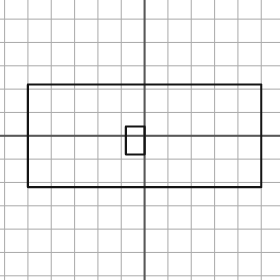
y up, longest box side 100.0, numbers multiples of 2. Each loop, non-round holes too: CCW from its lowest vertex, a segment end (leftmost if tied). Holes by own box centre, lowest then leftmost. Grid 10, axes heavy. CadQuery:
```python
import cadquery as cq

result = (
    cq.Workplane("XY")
    .moveTo(-50.0, -22.0)
    .lineTo(50.0, -22.0)
    .lineTo(50.0, 22.0)
    .lineTo(-50.0, 22.0)
    .close()
    .moveTo(-8.0, -8.0)
    .lineTo(0.0, -8.0)
    .lineTo(0.0, 4.0)
    .lineTo(-8.0, 4.0)
    .close()
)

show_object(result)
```